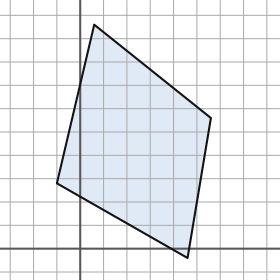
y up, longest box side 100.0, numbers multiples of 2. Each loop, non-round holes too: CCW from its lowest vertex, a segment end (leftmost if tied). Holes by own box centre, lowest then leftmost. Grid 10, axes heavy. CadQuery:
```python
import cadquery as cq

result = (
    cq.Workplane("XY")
    .moveTo(46.0, -4.0)
    .lineTo(56.0, 56.0)
    .lineTo(6.0, 96.0)
    .lineTo(-10.0, 28.0)
    .close()
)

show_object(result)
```